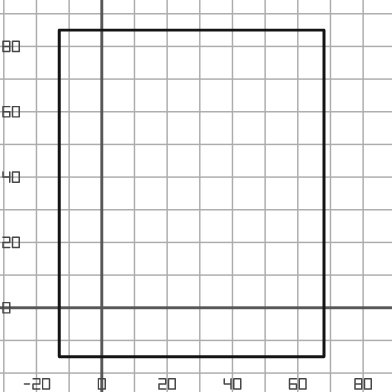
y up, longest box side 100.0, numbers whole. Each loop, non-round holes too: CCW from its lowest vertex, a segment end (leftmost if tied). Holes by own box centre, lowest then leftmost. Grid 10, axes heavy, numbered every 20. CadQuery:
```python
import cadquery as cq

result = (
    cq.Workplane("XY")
    .moveTo(-13.0, -15.0)
    .lineTo(68.0, -15.0)
    .lineTo(68.0, 85.0)
    .lineTo(-13.0, 85.0)
    .close()
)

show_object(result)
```